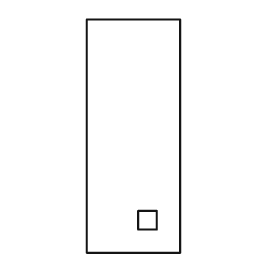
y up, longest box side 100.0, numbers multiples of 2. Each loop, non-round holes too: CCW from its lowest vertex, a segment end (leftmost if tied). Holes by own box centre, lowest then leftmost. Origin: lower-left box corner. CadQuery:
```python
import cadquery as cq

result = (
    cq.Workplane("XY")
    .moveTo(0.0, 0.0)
    .lineTo(40.0, 0.0)
    .lineTo(40.0, 100.0)
    .lineTo(0.0, 100.0)
    .close()
    .moveTo(22.0, 10.0)
    .lineTo(30.0, 10.0)
    .lineTo(30.0, 18.0)
    .lineTo(22.0, 18.0)
    .close()
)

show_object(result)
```